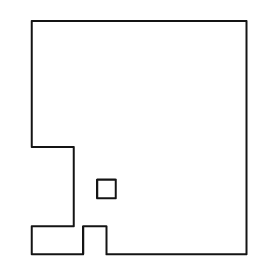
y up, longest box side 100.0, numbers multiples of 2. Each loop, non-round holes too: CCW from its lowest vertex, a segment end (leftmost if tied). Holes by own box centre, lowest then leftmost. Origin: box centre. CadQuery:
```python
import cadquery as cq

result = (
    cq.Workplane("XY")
    .moveTo(-46.0, -50.0)
    .lineTo(-24.0, -50.0)
    .lineTo(-24.0, -38.0)
    .lineTo(-14.0, -38.0)
    .lineTo(-14.0, -50.0)
    .lineTo(46.0, -50.0)
    .lineTo(46.0, 50.0)
    .lineTo(-46.0, 50.0)
    .lineTo(-46.0, -4.0)
    .lineTo(-28.0, -4.0)
    .lineTo(-28.0, -38.0)
    .lineTo(-46.0, -38.0)
    .close()
    .moveTo(-18.0, -26.0)
    .lineTo(-10.0, -26.0)
    .lineTo(-10.0, -18.0)
    .lineTo(-18.0, -18.0)
    .close()
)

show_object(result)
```